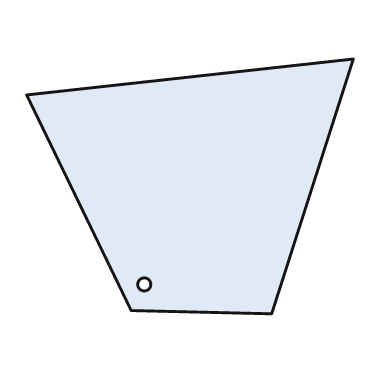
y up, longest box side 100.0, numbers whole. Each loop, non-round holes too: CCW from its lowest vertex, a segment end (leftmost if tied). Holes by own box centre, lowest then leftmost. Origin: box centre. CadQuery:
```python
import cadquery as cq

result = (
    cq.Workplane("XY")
    .moveTo(25.0, -39.0)
    .lineTo(50.0, 39.0)
    .lineTo(-50.0, 28.0)
    .lineTo(-18.0, -38.0)
    .close()
    .moveTo(-14.0, -30.0)
    .circle(2.0)
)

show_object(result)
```